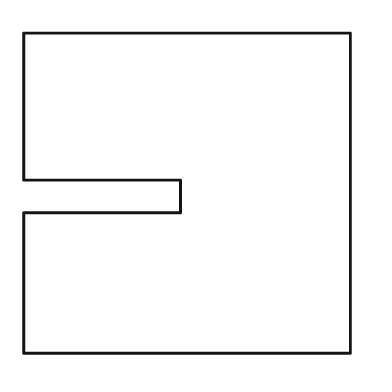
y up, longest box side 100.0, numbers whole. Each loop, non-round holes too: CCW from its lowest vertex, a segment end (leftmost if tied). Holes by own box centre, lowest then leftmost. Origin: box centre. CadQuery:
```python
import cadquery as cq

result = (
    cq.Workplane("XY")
    .moveTo(-50.0, -49.0)
    .lineTo(50.0, -49.0)
    .lineTo(50.0, 49.0)
    .lineTo(-50.0, 49.0)
    .lineTo(-50.0, 4.0)
    .lineTo(-2.0, 4.0)
    .lineTo(-2.0, -6.0)
    .lineTo(-50.0, -6.0)
    .close()
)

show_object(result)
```